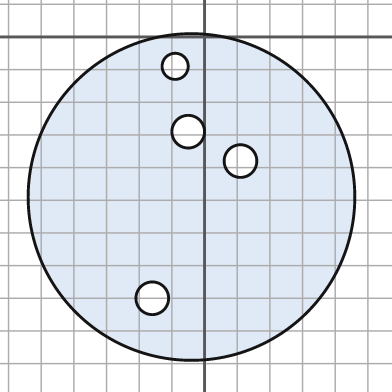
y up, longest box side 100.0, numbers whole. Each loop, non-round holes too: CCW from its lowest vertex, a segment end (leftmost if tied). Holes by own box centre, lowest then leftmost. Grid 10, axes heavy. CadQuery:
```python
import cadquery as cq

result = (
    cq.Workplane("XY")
    .moveTo(-4.0, -49.0)
    .circle(50.0)
    .moveTo(-16.0, -80.0)
    .circle(5.0)
    .moveTo(11.0, -38.0)
    .circle(5.0)
    .moveTo(-5.0, -29.0)
    .circle(5.0)
    .moveTo(-9.0, -9.0)
    .circle(4.0)
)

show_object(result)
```